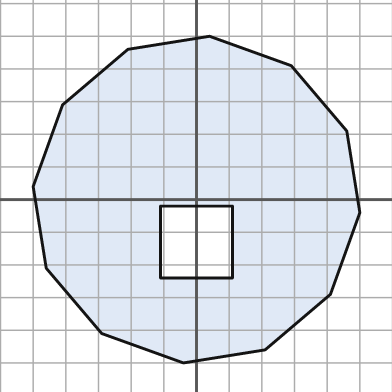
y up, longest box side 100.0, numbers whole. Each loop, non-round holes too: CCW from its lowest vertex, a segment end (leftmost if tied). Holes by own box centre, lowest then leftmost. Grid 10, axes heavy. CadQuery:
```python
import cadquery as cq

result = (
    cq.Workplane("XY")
    .moveTo(-4.0, -50.0)
    .lineTo(21.0, -46.0)
    .lineTo(41.0, -29.0)
    .lineTo(50.0, -4.0)
    .lineTo(46.0, 21.0)
    .lineTo(29.0, 41.0)
    .lineTo(4.0, 50.0)
    .lineTo(-21.0, 46.0)
    .lineTo(-41.0, 29.0)
    .lineTo(-50.0, 4.0)
    .lineTo(-46.0, -21.0)
    .lineTo(-29.0, -41.0)
    .close()
    .moveTo(-11.0, -24.0)
    .lineTo(11.0, -24.0)
    .lineTo(11.0, -2.0)
    .lineTo(-11.0, -2.0)
    .close()
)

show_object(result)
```